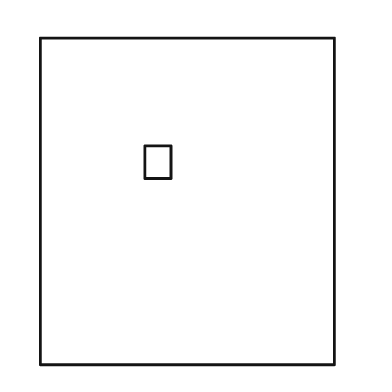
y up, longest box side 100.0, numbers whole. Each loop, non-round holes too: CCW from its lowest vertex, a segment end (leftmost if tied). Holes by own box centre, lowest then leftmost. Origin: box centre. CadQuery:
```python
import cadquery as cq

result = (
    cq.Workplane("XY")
    .moveTo(-45.0, -50.0)
    .lineTo(45.0, -50.0)
    .lineTo(45.0, 50.0)
    .lineTo(-45.0, 50.0)
    .close()
    .moveTo(-13.0, 7.0)
    .lineTo(-5.0, 7.0)
    .lineTo(-5.0, 17.0)
    .lineTo(-13.0, 17.0)
    .close()
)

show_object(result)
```